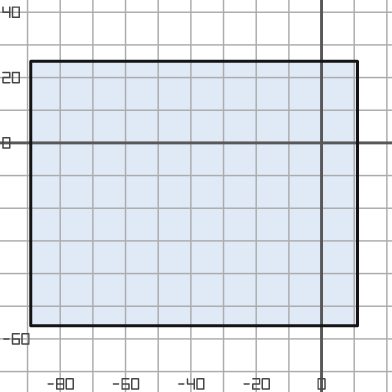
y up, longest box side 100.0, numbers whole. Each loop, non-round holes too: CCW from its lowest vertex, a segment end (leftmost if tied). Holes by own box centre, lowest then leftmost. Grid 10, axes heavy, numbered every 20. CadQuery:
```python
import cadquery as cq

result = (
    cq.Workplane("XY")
    .moveTo(-89.0, -56.0)
    .lineTo(11.0, -56.0)
    .lineTo(11.0, 25.0)
    .lineTo(-89.0, 25.0)
    .close()
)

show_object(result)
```